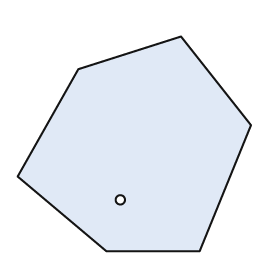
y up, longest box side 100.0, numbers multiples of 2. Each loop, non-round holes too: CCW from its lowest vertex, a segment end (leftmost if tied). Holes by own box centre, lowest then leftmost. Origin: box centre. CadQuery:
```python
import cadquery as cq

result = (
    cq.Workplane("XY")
    .moveTo(-12.0, -46.0)
    .lineTo(28.0, -46.0)
    .lineTo(50.0, 8.0)
    .lineTo(20.0, 46.0)
    .lineTo(-24.0, 32.0)
    .lineTo(-50.0, -14.0)
    .close()
    .moveTo(-6.0, -24.0)
    .circle(2.0)
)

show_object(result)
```